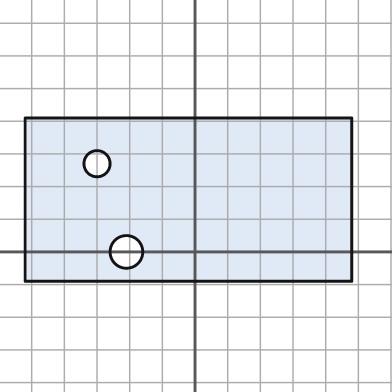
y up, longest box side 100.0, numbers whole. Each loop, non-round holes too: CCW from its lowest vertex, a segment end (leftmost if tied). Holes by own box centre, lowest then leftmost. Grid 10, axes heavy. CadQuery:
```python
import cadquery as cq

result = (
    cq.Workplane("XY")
    .moveTo(-52.0, -9.0)
    .lineTo(48.0, -9.0)
    .lineTo(48.0, 41.0)
    .lineTo(-52.0, 41.0)
    .close()
    .moveTo(-21.0, 0.0)
    .circle(5.0)
    .moveTo(-30.0, 27.0)
    .circle(4.0)
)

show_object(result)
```